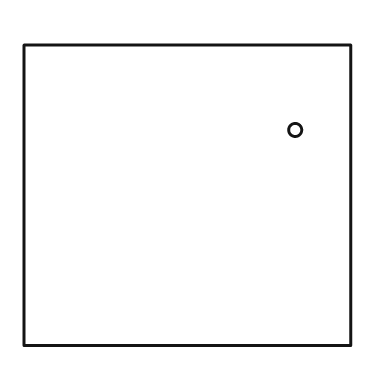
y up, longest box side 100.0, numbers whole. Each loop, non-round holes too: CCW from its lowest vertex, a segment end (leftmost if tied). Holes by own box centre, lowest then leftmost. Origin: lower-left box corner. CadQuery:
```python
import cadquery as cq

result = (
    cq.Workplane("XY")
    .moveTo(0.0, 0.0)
    .lineTo(100.0, 0.0)
    .lineTo(100.0, 92.0)
    .lineTo(0.0, 92.0)
    .close()
    .moveTo(83.0, 66.0)
    .circle(2.0)
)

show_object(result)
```